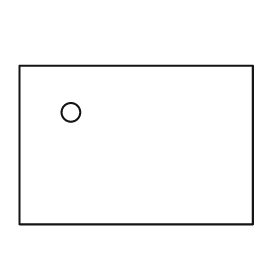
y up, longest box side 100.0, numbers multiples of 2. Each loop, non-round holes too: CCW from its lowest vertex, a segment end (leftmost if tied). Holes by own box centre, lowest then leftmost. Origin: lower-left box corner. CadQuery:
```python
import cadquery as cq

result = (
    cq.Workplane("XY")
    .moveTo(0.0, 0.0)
    .lineTo(100.0, 0.0)
    .lineTo(100.0, 68.0)
    .lineTo(0.0, 68.0)
    .close()
    .moveTo(22.0, 48.0)
    .circle(4.0)
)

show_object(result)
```